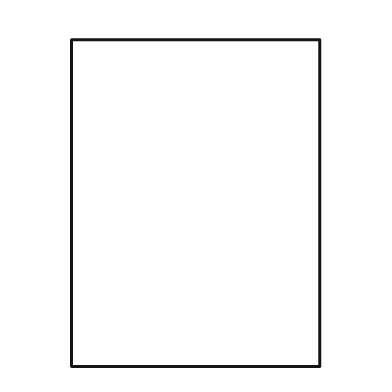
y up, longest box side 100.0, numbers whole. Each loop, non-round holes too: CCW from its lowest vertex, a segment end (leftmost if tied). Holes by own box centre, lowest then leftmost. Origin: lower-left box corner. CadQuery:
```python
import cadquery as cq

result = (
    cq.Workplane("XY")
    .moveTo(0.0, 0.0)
    .lineTo(76.0, 0.0)
    .lineTo(76.0, 100.0)
    .lineTo(0.0, 100.0)
    .close()
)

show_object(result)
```